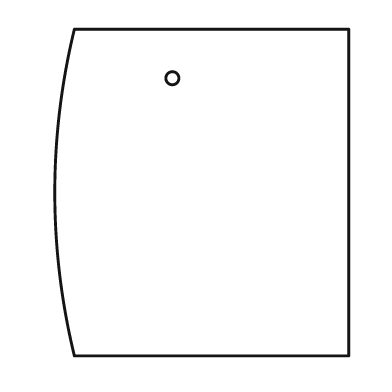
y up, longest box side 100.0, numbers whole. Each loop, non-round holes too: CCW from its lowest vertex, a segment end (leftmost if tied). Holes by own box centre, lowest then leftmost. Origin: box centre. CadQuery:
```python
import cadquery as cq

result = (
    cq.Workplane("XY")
    .moveTo(-39.0, -50.0)
    .lineTo(45.0, -50.0)
    .lineTo(45.0, 50.0)
    .lineTo(-39.0, 50.0)
    .threePointArc((-45.0, 0.0), (-39.0, -50.0))
    .close()
    .moveTo(-9.0, 35.0)
    .circle(2.0)
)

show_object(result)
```